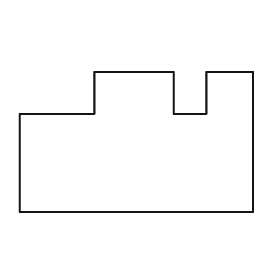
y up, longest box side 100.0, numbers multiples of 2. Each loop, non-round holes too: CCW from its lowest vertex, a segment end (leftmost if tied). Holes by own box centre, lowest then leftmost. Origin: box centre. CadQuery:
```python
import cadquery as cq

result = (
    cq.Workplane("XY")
    .moveTo(-50.0, -30.0)
    .lineTo(50.0, -30.0)
    .lineTo(50.0, 30.0)
    .lineTo(30.0, 30.0)
    .lineTo(30.0, 12.0)
    .lineTo(16.0, 12.0)
    .lineTo(16.0, 30.0)
    .lineTo(-18.0, 30.0)
    .lineTo(-18.0, 12.0)
    .lineTo(-50.0, 12.0)
    .close()
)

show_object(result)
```